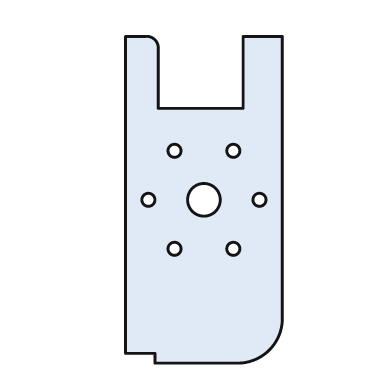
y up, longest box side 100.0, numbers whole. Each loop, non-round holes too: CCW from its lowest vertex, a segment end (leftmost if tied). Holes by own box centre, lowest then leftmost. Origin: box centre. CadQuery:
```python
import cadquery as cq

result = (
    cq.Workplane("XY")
    .moveTo(-15.0, -50.0)
    .lineTo(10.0, -50.0)
    .threePointArc((20.0, -46.0), (24.0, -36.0))
    .lineTo(24.0, 50.0)
    .lineTo(12.0, 50.0)
    .lineTo(12.0, 28.0)
    .lineTo(-14.0, 28.0)
    .lineTo(-14.0, 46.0)
    .threePointArc((-15.0, 49.0), (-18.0, 50.0))
    .lineTo(-24.0, 50.0)
    .lineTo(-24.0, -47.0)
    .lineTo(-15.0, -47.0)
    .close()
    .moveTo(-9.0, -15.0)
    .circle(2.0)
    .moveTo(9.0, -15.0)
    .circle(2.0)
    .moveTo(-17.0, 0.0)
    .circle(2.0)
    .moveTo(0.0, 0.0)
    .circle(5.0)
    .moveTo(17.0, 0.0)
    .circle(2.0)
    .moveTo(-9.0, 15.0)
    .circle(2.0)
    .moveTo(9.0, 15.0)
    .circle(2.0)
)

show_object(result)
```